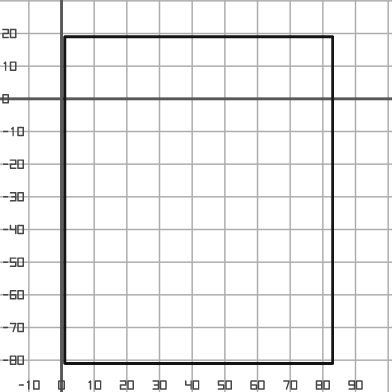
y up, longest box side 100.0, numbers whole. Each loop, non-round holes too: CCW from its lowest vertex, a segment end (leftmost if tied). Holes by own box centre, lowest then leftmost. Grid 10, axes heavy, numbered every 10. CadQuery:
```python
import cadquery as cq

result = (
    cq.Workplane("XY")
    .moveTo(1.0, -81.0)
    .lineTo(83.0, -81.0)
    .lineTo(83.0, 19.0)
    .lineTo(1.0, 19.0)
    .close()
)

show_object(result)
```